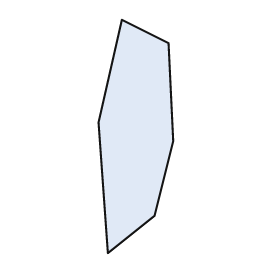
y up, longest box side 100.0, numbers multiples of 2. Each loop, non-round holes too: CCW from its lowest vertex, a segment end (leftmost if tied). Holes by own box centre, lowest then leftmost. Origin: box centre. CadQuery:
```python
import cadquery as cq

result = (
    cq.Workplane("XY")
    .moveTo(-12.0, -50.0)
    .lineTo(8.0, -34.0)
    .lineTo(16.0, -2.0)
    .lineTo(14.0, 40.0)
    .lineTo(-6.0, 50.0)
    .lineTo(-16.0, 6.0)
    .close()
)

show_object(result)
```